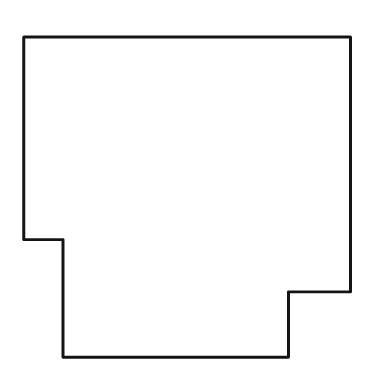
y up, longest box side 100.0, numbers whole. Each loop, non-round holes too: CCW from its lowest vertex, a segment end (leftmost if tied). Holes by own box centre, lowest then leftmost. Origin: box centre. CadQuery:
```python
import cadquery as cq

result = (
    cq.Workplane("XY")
    .moveTo(-38.0, -49.0)
    .lineTo(31.0, -49.0)
    .lineTo(31.0, -29.0)
    .lineTo(50.0, -29.0)
    .lineTo(50.0, 49.0)
    .lineTo(-50.0, 49.0)
    .lineTo(-50.0, -13.0)
    .lineTo(-38.0, -13.0)
    .close()
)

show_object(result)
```